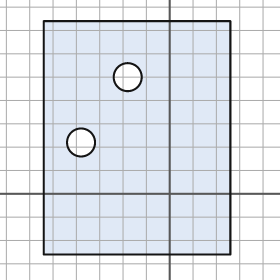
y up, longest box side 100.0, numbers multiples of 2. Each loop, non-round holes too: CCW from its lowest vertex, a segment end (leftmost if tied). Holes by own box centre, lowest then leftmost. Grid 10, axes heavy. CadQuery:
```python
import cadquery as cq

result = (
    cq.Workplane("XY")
    .moveTo(-54.0, -26.0)
    .lineTo(26.0, -26.0)
    .lineTo(26.0, 74.0)
    .lineTo(-54.0, 74.0)
    .close()
    .moveTo(-38.0, 22.0)
    .circle(6.0)
    .moveTo(-18.0, 50.0)
    .circle(6.0)
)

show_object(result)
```